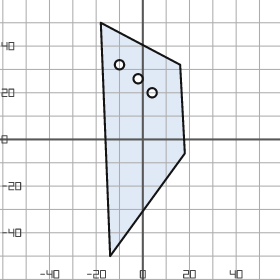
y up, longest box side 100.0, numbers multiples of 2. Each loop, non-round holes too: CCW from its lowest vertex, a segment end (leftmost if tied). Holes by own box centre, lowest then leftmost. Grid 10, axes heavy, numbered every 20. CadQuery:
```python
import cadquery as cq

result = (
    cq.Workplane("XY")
    .moveTo(-14.0, -50.0)
    .lineTo(18.0, -6.0)
    .lineTo(16.0, 32.0)
    .lineTo(-18.0, 50.0)
    .close()
    .moveTo(4.0, 20.0)
    .circle(2.0)
    .moveTo(-2.0, 26.0)
    .circle(2.0)
    .moveTo(-10.0, 32.0)
    .circle(2.0)
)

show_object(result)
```